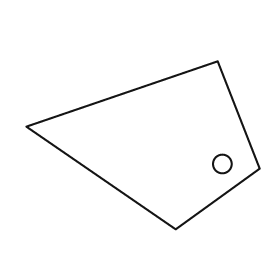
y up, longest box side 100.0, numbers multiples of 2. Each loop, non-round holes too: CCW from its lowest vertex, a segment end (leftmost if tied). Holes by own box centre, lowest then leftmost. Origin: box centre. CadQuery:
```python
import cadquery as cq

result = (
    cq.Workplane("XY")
    .moveTo(14.0, -36.0)
    .lineTo(50.0, -10.0)
    .lineTo(32.0, 36.0)
    .lineTo(-50.0, 8.0)
    .close()
    .moveTo(34.0, -8.0)
    .circle(4.0)
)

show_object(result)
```